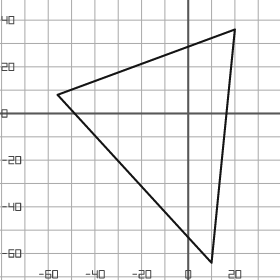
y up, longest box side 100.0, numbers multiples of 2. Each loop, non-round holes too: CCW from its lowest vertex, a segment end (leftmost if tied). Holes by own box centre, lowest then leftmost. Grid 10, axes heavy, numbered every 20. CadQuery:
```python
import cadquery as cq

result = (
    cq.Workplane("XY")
    .moveTo(10.0, -64.0)
    .lineTo(20.0, 36.0)
    .lineTo(-56.0, 8.0)
    .close()
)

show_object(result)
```